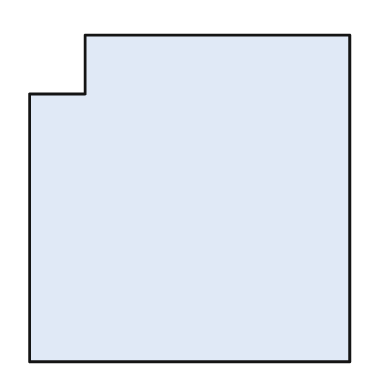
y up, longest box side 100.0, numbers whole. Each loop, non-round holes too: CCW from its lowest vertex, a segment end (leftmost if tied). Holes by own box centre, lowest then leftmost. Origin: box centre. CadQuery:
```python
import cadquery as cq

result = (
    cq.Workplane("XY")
    .moveTo(-49.0, -50.0)
    .lineTo(49.0, -50.0)
    .lineTo(49.0, 50.0)
    .lineTo(-32.0, 50.0)
    .lineTo(-32.0, 32.0)
    .lineTo(-49.0, 32.0)
    .close()
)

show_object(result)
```